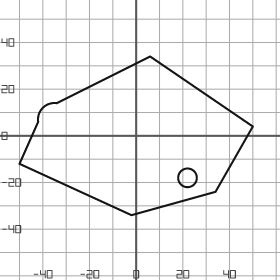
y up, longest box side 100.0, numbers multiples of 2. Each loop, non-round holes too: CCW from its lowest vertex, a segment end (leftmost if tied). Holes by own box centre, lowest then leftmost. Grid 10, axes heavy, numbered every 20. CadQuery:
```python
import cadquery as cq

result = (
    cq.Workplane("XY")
    .moveTo(-2.0, -34.0)
    .lineTo(34.0, -24.0)
    .lineTo(50.0, 4.0)
    .lineTo(6.0, 34.0)
    .lineTo(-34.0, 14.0)
    .threePointArc((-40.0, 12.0), (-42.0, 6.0))
    .lineTo(-50.0, -12.0)
    .close()
    .moveTo(22.0, -18.0)
    .circle(4.0)
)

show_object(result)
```